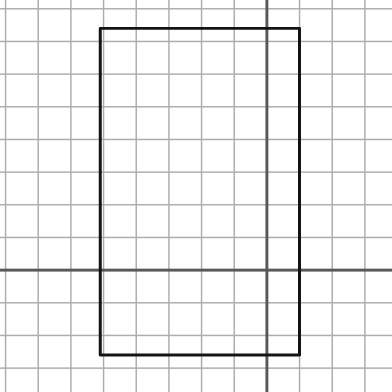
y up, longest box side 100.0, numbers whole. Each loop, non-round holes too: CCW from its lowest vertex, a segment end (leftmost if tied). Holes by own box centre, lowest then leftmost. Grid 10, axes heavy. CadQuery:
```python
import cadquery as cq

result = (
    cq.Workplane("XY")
    .moveTo(-51.0, -26.0)
    .lineTo(10.0, -26.0)
    .lineTo(10.0, 74.0)
    .lineTo(-51.0, 74.0)
    .close()
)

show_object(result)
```